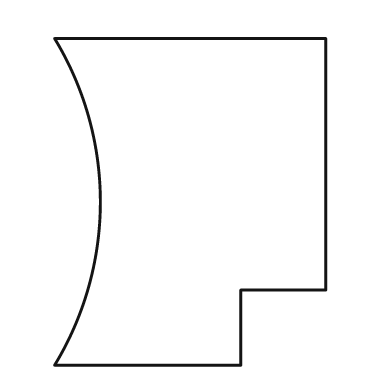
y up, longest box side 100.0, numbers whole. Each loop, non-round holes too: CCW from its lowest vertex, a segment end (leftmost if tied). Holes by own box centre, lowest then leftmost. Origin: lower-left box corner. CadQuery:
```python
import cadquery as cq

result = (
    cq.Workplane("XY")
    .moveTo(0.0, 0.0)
    .lineTo(57.0, 0.0)
    .lineTo(57.0, 23.0)
    .lineTo(83.0, 23.0)
    .lineTo(83.0, 100.0)
    .lineTo(0.0, 100.0)
    .threePointArc((14.0, 50.0), (0.0, 0.0))
    .close()
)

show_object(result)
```